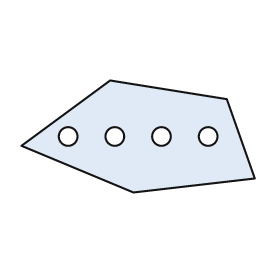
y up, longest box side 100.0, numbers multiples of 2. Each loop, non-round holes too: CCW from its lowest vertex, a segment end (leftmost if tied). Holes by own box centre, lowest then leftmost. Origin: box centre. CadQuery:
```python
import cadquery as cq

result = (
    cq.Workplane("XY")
    .moveTo(-2.0, -24.0)
    .lineTo(50.0, -18.0)
    .lineTo(38.0, 16.0)
    .lineTo(-12.0, 24.0)
    .lineTo(-50.0, -4.0)
    .close()
    .moveTo(-30.0, 0.0)
    .circle(4.0)
    .moveTo(-10.0, 0.0)
    .circle(4.0)
    .moveTo(10.0, 0.0)
    .circle(4.0)
    .moveTo(30.0, 0.0)
    .circle(4.0)
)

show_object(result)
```